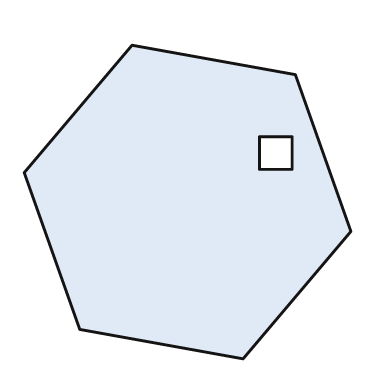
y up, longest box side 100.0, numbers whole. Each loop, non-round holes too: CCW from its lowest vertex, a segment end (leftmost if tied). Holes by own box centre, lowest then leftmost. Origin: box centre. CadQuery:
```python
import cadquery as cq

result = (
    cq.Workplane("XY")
    .moveTo(17.0, -48.0)
    .lineTo(50.0, -9.0)
    .lineTo(33.0, 39.0)
    .lineTo(-17.0, 48.0)
    .lineTo(-50.0, 9.0)
    .lineTo(-33.0, -39.0)
    .close()
    .moveTo(22.0, 10.0)
    .lineTo(32.0, 10.0)
    .lineTo(32.0, 20.0)
    .lineTo(22.0, 20.0)
    .close()
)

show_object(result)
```